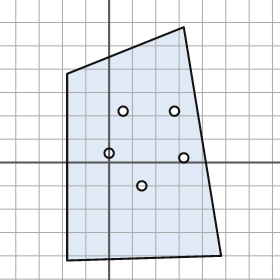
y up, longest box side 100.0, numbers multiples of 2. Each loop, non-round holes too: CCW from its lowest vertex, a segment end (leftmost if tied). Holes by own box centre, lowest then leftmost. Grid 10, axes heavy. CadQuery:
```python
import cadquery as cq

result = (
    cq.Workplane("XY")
    .moveTo(-18.0, -42.0)
    .lineTo(48.0, -40.0)
    .lineTo(32.0, 58.0)
    .lineTo(-18.0, 38.0)
    .close()
    .moveTo(14.0, -10.0)
    .circle(2.0)
    .moveTo(32.0, 2.0)
    .circle(2.0)
    .moveTo(0.0, 4.0)
    .circle(2.0)
    .moveTo(6.0, 22.0)
    .circle(2.0)
    .moveTo(28.0, 22.0)
    .circle(2.0)
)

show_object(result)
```